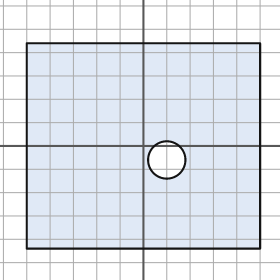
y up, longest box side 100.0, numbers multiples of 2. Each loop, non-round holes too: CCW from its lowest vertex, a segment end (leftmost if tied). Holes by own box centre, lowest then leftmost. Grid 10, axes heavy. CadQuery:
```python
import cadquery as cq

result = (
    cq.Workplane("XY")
    .moveTo(-50.0, -44.0)
    .lineTo(50.0, -44.0)
    .lineTo(50.0, 44.0)
    .lineTo(-50.0, 44.0)
    .close()
    .moveTo(10.0, -6.0)
    .circle(8.0)
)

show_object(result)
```